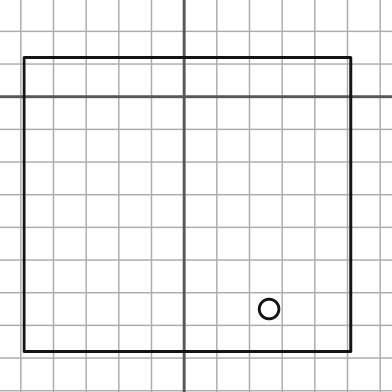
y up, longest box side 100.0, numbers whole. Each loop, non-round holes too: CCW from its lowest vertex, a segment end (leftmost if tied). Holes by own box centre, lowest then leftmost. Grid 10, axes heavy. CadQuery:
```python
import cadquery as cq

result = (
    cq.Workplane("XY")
    .moveTo(-49.0, -78.0)
    .lineTo(51.0, -78.0)
    .lineTo(51.0, 12.0)
    .lineTo(-49.0, 12.0)
    .close()
    .moveTo(26.0, -65.0)
    .circle(3.0)
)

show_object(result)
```